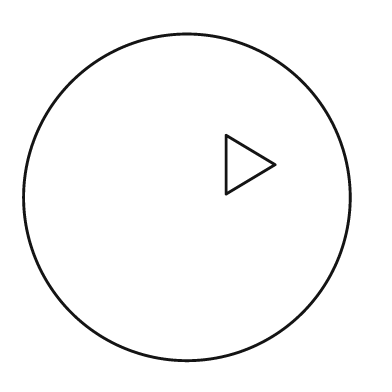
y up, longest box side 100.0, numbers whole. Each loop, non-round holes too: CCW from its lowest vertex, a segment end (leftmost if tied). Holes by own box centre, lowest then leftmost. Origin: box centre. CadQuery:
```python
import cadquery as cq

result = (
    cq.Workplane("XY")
    .moveTo(0.0, 0.0)
    .circle(50.0)
    .moveTo(12.0, 1.0)
    .lineTo(27.0, 10.0)
    .lineTo(12.0, 19.0)
    .close()
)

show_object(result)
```